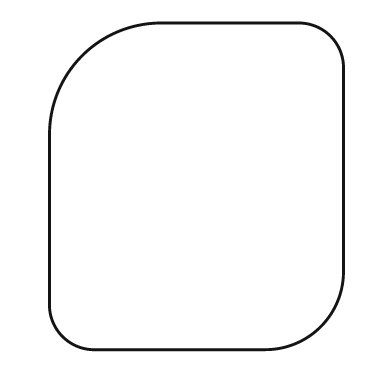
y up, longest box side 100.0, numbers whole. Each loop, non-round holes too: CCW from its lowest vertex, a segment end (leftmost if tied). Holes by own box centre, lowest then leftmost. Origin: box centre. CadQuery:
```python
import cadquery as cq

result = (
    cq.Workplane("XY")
    .moveTo(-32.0, -50.0)
    .lineTo(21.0, -50.0)
    .threePointArc((38.0, -43.0), (45.0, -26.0))
    .lineTo(45.0, 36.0)
    .threePointArc((41.0, 46.0), (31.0, 50.0))
    .lineTo(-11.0, 50.0)
    .threePointArc((-35.0, 40.0), (-45.0, 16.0))
    .lineTo(-45.0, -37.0)
    .threePointArc((-41.0, -46.0), (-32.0, -50.0))
    .close()
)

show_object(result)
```